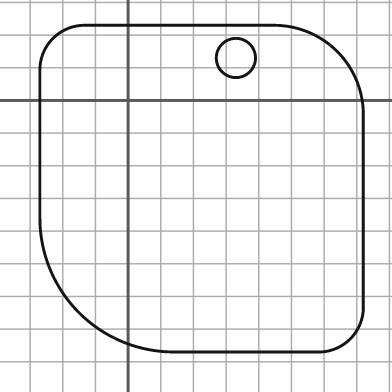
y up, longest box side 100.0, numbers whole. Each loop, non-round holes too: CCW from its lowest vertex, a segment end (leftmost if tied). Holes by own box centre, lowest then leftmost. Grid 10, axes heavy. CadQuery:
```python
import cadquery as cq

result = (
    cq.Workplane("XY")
    .moveTo(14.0, -77.0)
    .lineTo(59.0, -77.0)
    .threePointArc((68.0, -73.0), (72.0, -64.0))
    .lineTo(72.0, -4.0)
    .threePointArc((64.0, 15.0), (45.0, 23.0))
    .lineTo(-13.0, 23.0)
    .threePointArc((-23.0, 19.0), (-27.0, 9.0))
    .lineTo(-27.0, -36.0)
    .threePointArc((-15.0, -65.0), (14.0, -77.0))
    .close()
    .moveTo(33.0, 13.0)
    .circle(6.0)
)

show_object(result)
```